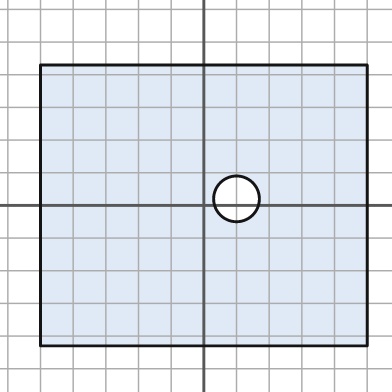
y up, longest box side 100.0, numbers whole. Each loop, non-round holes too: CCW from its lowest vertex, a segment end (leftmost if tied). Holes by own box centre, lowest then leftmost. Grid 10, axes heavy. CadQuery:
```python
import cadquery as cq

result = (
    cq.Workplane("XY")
    .moveTo(-50.0, -43.0)
    .lineTo(50.0, -43.0)
    .lineTo(50.0, 43.0)
    .lineTo(-50.0, 43.0)
    .close()
    .moveTo(10.0, 2.0)
    .circle(7.0)
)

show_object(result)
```